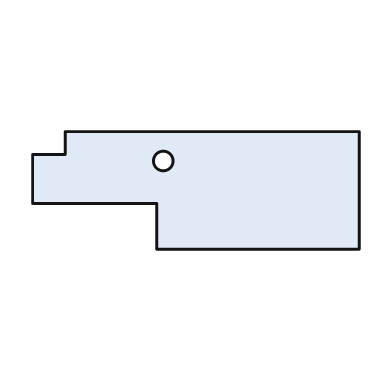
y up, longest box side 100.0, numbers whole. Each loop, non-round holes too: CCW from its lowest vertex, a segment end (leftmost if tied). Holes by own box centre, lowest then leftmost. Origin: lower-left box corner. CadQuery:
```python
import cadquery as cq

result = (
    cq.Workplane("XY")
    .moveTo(38.0, 0.0)
    .lineTo(100.0, 0.0)
    .lineTo(100.0, 36.0)
    .lineTo(10.0, 36.0)
    .lineTo(10.0, 29.0)
    .lineTo(0.0, 29.0)
    .lineTo(0.0, 14.0)
    .lineTo(38.0, 14.0)
    .close()
    .moveTo(40.0, 27.0)
    .circle(3.0)
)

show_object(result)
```